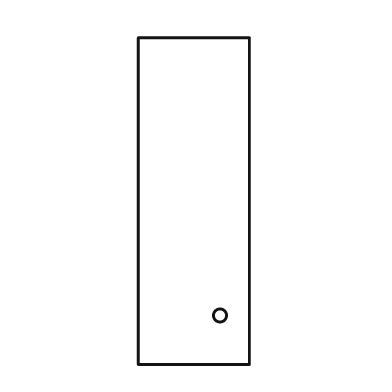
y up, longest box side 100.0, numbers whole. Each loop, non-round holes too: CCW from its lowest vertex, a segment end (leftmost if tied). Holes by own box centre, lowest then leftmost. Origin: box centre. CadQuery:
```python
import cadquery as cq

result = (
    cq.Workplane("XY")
    .moveTo(-17.0, -50.0)
    .lineTo(17.0, -50.0)
    .lineTo(17.0, 50.0)
    .lineTo(-17.0, 50.0)
    .close()
    .moveTo(8.0, -35.0)
    .circle(2.0)
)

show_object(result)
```